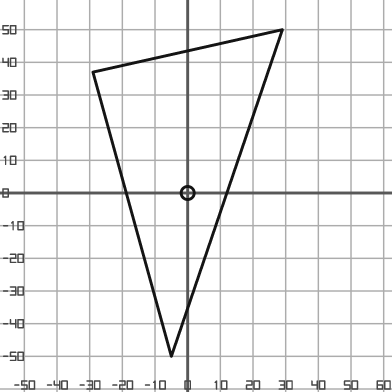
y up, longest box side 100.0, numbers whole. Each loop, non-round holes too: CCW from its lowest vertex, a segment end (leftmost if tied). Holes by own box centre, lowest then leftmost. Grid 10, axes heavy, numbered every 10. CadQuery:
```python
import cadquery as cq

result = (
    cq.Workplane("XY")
    .moveTo(-5.0, -50.0)
    .lineTo(29.0, 50.0)
    .lineTo(-29.0, 37.0)
    .close()
    .moveTo(0.0, 0.0)
    .circle(2.0)
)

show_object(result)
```